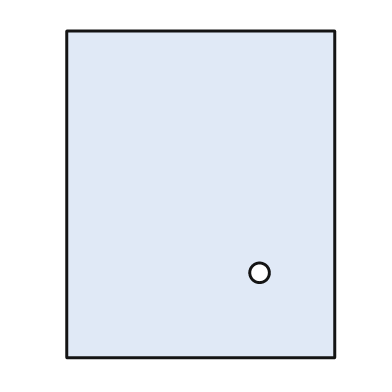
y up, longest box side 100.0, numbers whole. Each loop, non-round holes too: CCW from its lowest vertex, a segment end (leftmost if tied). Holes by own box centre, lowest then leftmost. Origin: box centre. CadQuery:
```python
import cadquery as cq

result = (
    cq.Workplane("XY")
    .moveTo(-41.0, -50.0)
    .lineTo(41.0, -50.0)
    .lineTo(41.0, 50.0)
    .lineTo(-41.0, 50.0)
    .close()
    .moveTo(18.0, -24.0)
    .circle(3.0)
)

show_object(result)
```